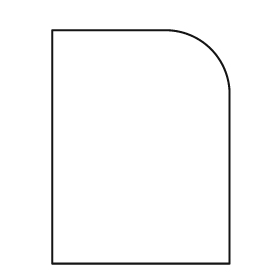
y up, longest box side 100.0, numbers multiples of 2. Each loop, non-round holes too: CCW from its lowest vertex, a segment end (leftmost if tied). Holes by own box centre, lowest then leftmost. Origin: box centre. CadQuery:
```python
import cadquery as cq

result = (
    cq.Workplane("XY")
    .moveTo(-38.0, -50.0)
    .lineTo(38.0, -50.0)
    .lineTo(38.0, 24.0)
    .threePointArc((30.0, 42.0), (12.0, 50.0))
    .lineTo(-38.0, 50.0)
    .close()
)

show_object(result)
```